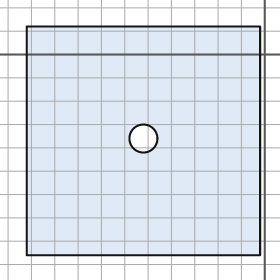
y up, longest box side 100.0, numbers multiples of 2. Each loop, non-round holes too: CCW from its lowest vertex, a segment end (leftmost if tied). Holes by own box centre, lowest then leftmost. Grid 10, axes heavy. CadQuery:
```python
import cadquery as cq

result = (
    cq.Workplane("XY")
    .moveTo(-102.0, -86.0)
    .lineTo(-2.0, -86.0)
    .lineTo(-2.0, 12.0)
    .lineTo(-102.0, 12.0)
    .close()
    .moveTo(-52.0, -36.0)
    .circle(6.0)
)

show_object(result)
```